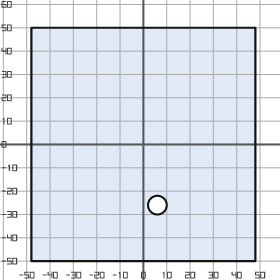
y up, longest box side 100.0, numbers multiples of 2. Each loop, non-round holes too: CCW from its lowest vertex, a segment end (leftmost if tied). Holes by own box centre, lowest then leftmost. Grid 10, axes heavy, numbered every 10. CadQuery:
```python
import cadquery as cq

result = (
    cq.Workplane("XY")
    .moveTo(-48.0, -50.0)
    .lineTo(48.0, -50.0)
    .lineTo(48.0, 50.0)
    .lineTo(-48.0, 50.0)
    .close()
    .moveTo(6.0, -26.0)
    .circle(4.0)
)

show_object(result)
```